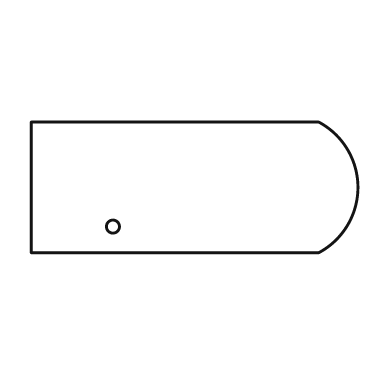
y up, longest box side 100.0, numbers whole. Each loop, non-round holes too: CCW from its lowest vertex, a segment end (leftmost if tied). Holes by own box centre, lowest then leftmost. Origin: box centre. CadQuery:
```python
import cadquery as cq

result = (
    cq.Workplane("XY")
    .moveTo(-50.0, -20.0)
    .lineTo(38.0, -20.0)
    .threePointArc((50.0, 0.0), (38.0, 20.0))
    .lineTo(-50.0, 20.0)
    .close()
    .moveTo(-25.0, -12.0)
    .circle(2.0)
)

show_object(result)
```